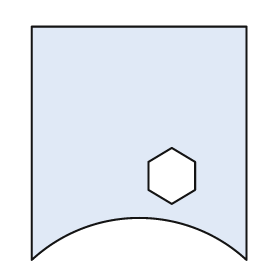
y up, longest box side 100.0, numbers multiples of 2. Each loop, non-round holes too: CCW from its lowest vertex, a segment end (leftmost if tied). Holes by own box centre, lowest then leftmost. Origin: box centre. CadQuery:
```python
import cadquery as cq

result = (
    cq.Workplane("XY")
    .moveTo(-46.0, -50.0)
    .threePointArc((0.0, -32.0), (46.0, -50.0))
    .lineTo(46.0, 50.0)
    .lineTo(-46.0, 50.0)
    .close()
    .moveTo(14.0, -26.0)
    .lineTo(24.0, -20.0)
    .lineTo(24.0, -8.0)
    .lineTo(14.0, -2.0)
    .lineTo(4.0, -8.0)
    .lineTo(4.0, -20.0)
    .close()
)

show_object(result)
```